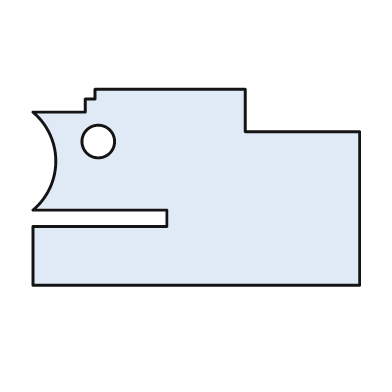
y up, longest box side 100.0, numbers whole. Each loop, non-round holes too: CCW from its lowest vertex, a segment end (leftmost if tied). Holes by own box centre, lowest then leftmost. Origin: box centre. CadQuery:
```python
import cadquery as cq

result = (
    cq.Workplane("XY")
    .moveTo(-50.0, -30.0)
    .lineTo(50.0, -30.0)
    .lineTo(50.0, 17.0)
    .lineTo(15.0, 17.0)
    .lineTo(15.0, 30.0)
    .lineTo(-31.0, 30.0)
    .lineTo(-31.0, 27.0)
    .lineTo(-34.0, 27.0)
    .lineTo(-34.0, 23.0)
    .lineTo(-50.0, 23.0)
    .threePointArc((-43.0, 8.0), (-50.0, -7.0))
    .lineTo(-9.0, -7.0)
    .lineTo(-9.0, -12.0)
    .lineTo(-50.0, -12.0)
    .close()
    .moveTo(-30.0, 14.0)
    .circle(5.0)
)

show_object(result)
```